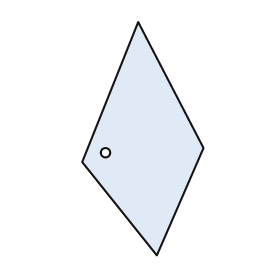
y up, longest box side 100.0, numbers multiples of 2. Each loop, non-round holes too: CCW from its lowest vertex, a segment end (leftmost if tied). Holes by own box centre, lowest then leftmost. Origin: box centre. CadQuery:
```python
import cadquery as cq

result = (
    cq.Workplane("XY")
    .moveTo(6.0, -50.0)
    .lineTo(26.0, -4.0)
    .lineTo(-2.0, 50.0)
    .lineTo(-26.0, -10.0)
    .close()
    .moveTo(-16.0, -6.0)
    .circle(2.0)
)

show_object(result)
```